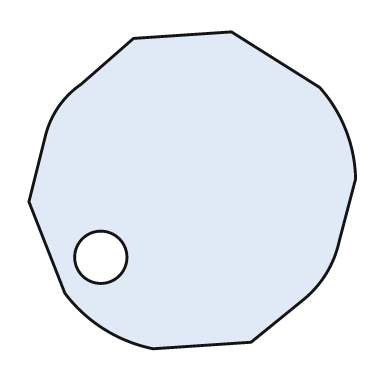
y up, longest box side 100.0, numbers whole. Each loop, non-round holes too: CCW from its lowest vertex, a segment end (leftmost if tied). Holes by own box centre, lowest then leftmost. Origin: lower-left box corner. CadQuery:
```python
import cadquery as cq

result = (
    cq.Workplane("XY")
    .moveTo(38.0, 0.0)
    .lineTo(68.0, 2.0)
    .lineTo(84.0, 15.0)
    .threePointArc((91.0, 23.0), (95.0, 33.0))
    .lineTo(100.0, 52.0)
    .threePointArc((97.0, 67.0), (89.0, 80.0))
    .lineTo(62.0, 97.0)
    .lineTo(32.0, 95.0)
    .lineTo(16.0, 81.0)
    .threePointArc((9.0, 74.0), (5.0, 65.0))
    .lineTo(0.0, 45.0)
    .lineTo(11.0, 17.0)
    .threePointArc((23.0, 6.0), (38.0, 0.0))
    .close()
    .moveTo(22.0, 28.0)
    .circle(8.0)
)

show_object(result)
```